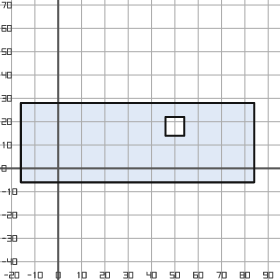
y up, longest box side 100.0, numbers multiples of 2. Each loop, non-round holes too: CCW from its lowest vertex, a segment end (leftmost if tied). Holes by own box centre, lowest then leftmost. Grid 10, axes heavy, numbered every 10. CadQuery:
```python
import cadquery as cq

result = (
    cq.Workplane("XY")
    .moveTo(-16.0, -6.0)
    .lineTo(84.0, -6.0)
    .lineTo(84.0, 28.0)
    .lineTo(-16.0, 28.0)
    .close()
    .moveTo(46.0, 14.0)
    .lineTo(54.0, 14.0)
    .lineTo(54.0, 22.0)
    .lineTo(46.0, 22.0)
    .close()
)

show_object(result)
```